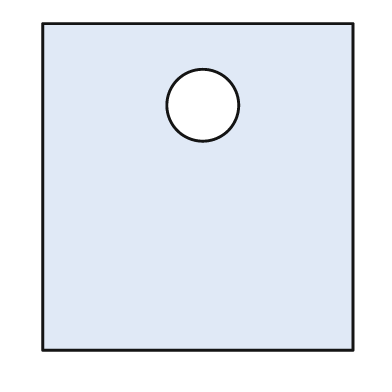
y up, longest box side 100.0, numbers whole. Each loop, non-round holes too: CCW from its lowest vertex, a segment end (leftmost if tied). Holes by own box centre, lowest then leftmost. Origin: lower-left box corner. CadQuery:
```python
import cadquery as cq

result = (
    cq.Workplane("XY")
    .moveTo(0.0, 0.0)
    .lineTo(95.0, 0.0)
    .lineTo(95.0, 100.0)
    .lineTo(0.0, 100.0)
    .close()
    .moveTo(49.0, 75.0)
    .circle(11.0)
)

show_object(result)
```